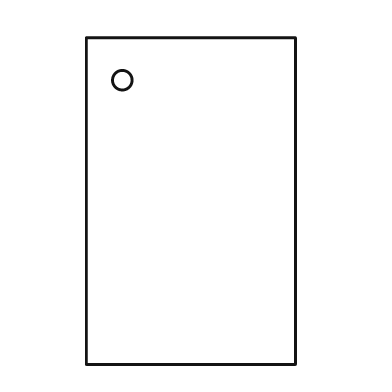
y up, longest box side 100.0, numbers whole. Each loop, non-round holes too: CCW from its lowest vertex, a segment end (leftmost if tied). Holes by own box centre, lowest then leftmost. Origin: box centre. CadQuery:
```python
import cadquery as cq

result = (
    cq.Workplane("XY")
    .moveTo(-32.0, -50.0)
    .lineTo(32.0, -50.0)
    .lineTo(32.0, 50.0)
    .lineTo(-32.0, 50.0)
    .close()
    .moveTo(-21.0, 37.0)
    .circle(3.0)
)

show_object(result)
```